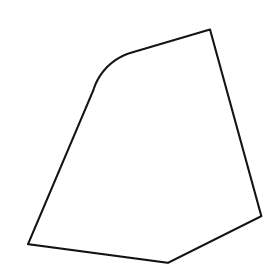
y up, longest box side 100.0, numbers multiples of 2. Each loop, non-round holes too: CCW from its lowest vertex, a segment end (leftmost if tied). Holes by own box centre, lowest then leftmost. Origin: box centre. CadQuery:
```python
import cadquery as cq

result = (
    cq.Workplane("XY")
    .moveTo(10.0, -50.0)
    .lineTo(50.0, -30.0)
    .lineTo(28.0, 50.0)
    .lineTo(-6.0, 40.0)
    .threePointArc((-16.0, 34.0), (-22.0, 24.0))
    .lineTo(-50.0, -42.0)
    .close()
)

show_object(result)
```